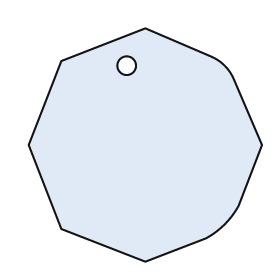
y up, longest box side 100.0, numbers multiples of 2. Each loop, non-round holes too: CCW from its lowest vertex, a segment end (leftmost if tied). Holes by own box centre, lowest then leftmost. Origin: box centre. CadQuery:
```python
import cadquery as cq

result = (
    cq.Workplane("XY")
    .moveTo(0.0, -50.0)
    .lineTo(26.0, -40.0)
    .threePointArc((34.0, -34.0), (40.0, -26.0))
    .lineTo(50.0, 0.0)
    .lineTo(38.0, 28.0)
    .threePointArc((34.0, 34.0), (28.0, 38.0))
    .lineTo(0.0, 50.0)
    .lineTo(-36.0, 36.0)
    .lineTo(-50.0, 0.0)
    .lineTo(-36.0, -36.0)
    .close()
    .moveTo(-8.0, 34.0)
    .circle(4.0)
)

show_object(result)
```